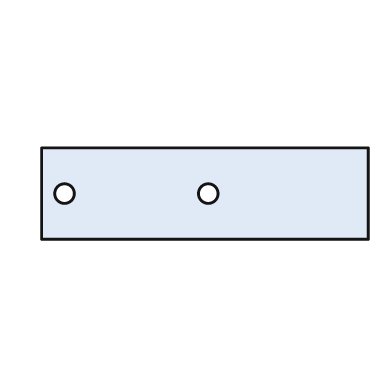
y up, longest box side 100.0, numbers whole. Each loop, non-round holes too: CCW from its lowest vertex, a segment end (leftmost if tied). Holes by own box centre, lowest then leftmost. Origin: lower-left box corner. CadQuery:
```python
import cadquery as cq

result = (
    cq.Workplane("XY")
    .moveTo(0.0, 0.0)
    .lineTo(100.0, 0.0)
    .lineTo(100.0, 28.0)
    .lineTo(0.0, 28.0)
    .close()
    .moveTo(7.0, 14.0)
    .circle(3.0)
    .moveTo(51.0, 14.0)
    .circle(3.0)
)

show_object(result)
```